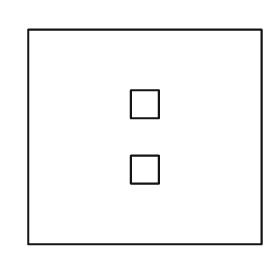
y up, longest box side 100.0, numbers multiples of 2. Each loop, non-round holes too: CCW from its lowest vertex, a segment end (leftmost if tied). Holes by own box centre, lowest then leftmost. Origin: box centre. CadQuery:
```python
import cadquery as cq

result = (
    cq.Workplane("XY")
    .moveTo(-50.0, -46.0)
    .lineTo(50.0, -46.0)
    .lineTo(50.0, 46.0)
    .lineTo(-50.0, 46.0)
    .close()
    .moveTo(-6.0, -20.0)
    .lineTo(6.0, -20.0)
    .lineTo(6.0, -8.0)
    .lineTo(-6.0, -8.0)
    .close()
    .moveTo(-6.0, 8.0)
    .lineTo(6.0, 8.0)
    .lineTo(6.0, 20.0)
    .lineTo(-6.0, 20.0)
    .close()
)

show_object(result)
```